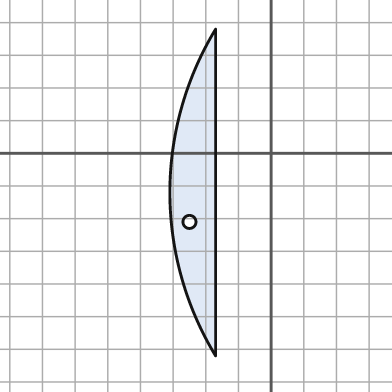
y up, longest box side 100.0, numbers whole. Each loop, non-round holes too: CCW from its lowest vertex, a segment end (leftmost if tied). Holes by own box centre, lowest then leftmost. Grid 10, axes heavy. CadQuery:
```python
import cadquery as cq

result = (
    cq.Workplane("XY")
    .moveTo(-17.0, -62.0)
    .lineTo(-17.0, 38.0)
    .threePointArc((-31.0, -12.0), (-17.0, -62.0))
    .close()
    .moveTo(-25.0, -21.0)
    .circle(2.0)
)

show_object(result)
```